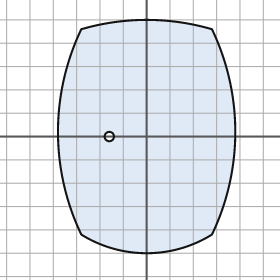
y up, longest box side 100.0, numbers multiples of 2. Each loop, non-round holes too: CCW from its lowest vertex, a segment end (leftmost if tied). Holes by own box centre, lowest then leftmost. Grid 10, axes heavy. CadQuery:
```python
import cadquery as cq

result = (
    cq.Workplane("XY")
    .moveTo(-28.0, -42.0)
    .threePointArc((0.0, -50.0), (28.0, -42.0))
    .threePointArc((38.0, 2.0), (28.0, 46.0))
    .threePointArc((0.0, 50.0), (-28.0, 46.0))
    .threePointArc((-38.0, 2.0), (-28.0, -42.0))
    .close()
    .moveTo(-16.0, 0.0)
    .circle(2.0)
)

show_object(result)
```